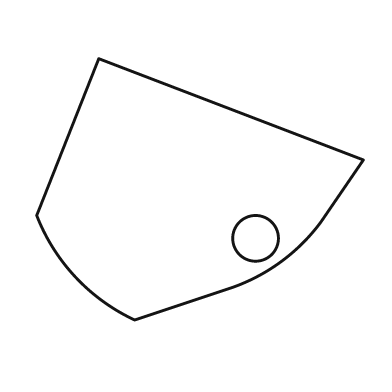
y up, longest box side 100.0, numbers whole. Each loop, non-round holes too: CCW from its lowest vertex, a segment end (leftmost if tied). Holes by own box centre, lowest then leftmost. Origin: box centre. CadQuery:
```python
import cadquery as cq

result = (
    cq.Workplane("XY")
    .moveTo(-20.0, -40.0)
    .lineTo(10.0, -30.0)
    .threePointArc((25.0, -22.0), (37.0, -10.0))
    .lineTo(50.0, 9.0)
    .lineTo(-31.0, 40.0)
    .lineTo(-50.0, -8.0)
    .threePointArc((-38.0, -27.0), (-20.0, -40.0))
    .close()
    .moveTo(17.0, -15.0)
    .circle(7.0)
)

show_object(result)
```